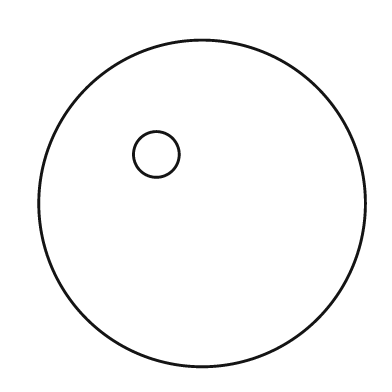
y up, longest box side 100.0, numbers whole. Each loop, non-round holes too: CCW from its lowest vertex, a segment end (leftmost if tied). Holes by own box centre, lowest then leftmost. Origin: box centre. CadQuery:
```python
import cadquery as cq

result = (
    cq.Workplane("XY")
    .moveTo(0.0, 0.0)
    .circle(50.0)
    .moveTo(-14.0, 15.0)
    .circle(7.0)
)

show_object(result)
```